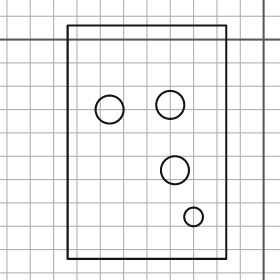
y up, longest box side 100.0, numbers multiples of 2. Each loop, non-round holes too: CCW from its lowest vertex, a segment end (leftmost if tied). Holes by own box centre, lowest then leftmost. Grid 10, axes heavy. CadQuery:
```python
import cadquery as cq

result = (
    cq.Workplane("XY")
    .moveTo(-84.0, -94.0)
    .lineTo(-16.0, -94.0)
    .lineTo(-16.0, 6.0)
    .lineTo(-84.0, 6.0)
    .close()
    .moveTo(-30.0, -76.0)
    .circle(4.0)
    .moveTo(-38.0, -56.0)
    .circle(6.0)
    .moveTo(-66.0, -30.0)
    .circle(6.0)
    .moveTo(-40.0, -28.0)
    .circle(6.0)
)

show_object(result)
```